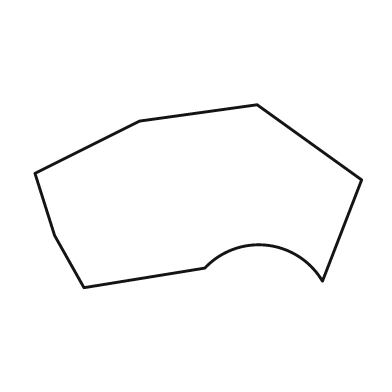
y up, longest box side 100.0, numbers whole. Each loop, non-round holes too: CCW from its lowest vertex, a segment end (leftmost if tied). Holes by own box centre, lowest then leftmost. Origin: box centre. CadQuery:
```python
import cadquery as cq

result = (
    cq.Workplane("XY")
    .moveTo(-35.0, -28.0)
    .lineTo(2.0, -22.0)
    .threePointArc((21.0, -15.0), (38.0, -26.0))
    .lineTo(50.0, 5.0)
    .lineTo(18.0, 28.0)
    .lineTo(-18.0, 23.0)
    .lineTo(-50.0, 7.0)
    .lineTo(-44.0, -12.0)
    .close()
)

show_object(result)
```